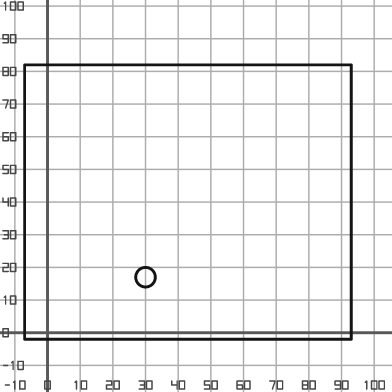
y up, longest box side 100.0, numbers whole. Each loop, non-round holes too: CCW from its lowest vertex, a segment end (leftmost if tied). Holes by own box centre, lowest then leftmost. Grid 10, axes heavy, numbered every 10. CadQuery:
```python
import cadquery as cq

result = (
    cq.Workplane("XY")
    .moveTo(-7.0, -2.0)
    .lineTo(93.0, -2.0)
    .lineTo(93.0, 82.0)
    .lineTo(-7.0, 82.0)
    .close()
    .moveTo(30.0, 17.0)
    .circle(3.0)
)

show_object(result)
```